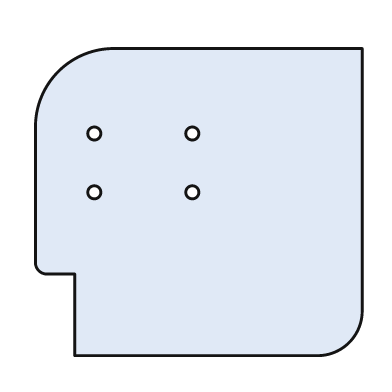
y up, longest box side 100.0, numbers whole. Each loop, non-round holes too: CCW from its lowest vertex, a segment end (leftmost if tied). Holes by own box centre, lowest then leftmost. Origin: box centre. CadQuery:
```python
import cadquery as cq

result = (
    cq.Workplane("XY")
    .moveTo(-38.0, -47.0)
    .lineTo(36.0, -47.0)
    .threePointArc((46.0, -43.0), (50.0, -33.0))
    .lineTo(50.0, 47.0)
    .lineTo(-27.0, 47.0)
    .threePointArc((-43.0, 40.0), (-50.0, 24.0))
    .lineTo(-50.0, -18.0)
    .threePointArc((-49.0, -21.0), (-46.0, -22.0))
    .lineTo(-38.0, -22.0)
    .close()
    .moveTo(-32.0, 3.0)
    .circle(2.0)
    .moveTo(-2.0, 3.0)
    .circle(2.0)
    .moveTo(-32.0, 21.0)
    .circle(2.0)
    .moveTo(-2.0, 21.0)
    .circle(2.0)
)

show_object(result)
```